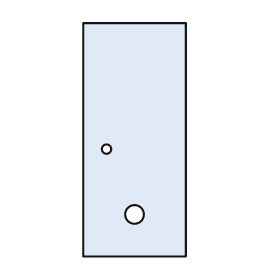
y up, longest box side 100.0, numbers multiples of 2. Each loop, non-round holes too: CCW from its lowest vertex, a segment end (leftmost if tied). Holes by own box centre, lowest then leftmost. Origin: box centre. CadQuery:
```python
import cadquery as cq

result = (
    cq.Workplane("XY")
    .moveTo(-22.0, -50.0)
    .lineTo(22.0, -50.0)
    .lineTo(22.0, 50.0)
    .lineTo(-22.0, 50.0)
    .close()
    .moveTo(0.0, -32.0)
    .circle(4.0)
    .moveTo(-12.0, -4.0)
    .circle(2.0)
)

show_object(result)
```